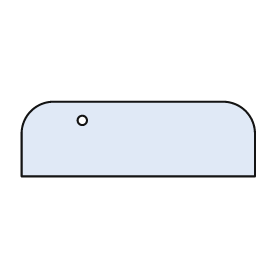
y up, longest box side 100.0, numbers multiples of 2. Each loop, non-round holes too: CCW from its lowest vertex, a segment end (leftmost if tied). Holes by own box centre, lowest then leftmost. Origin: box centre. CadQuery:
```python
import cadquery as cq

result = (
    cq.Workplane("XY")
    .moveTo(-50.0, -16.0)
    .lineTo(50.0, -16.0)
    .lineTo(50.0, 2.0)
    .threePointArc((46.0, 12.0), (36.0, 16.0))
    .lineTo(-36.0, 16.0)
    .threePointArc((-46.0, 12.0), (-50.0, 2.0))
    .close()
    .moveTo(-24.0, 8.0)
    .circle(2.0)
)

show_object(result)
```